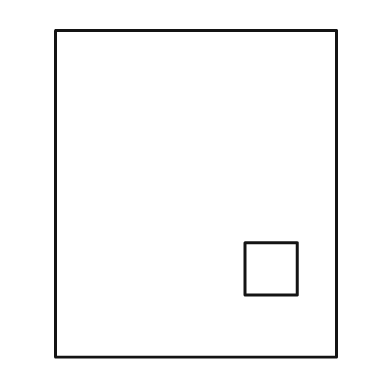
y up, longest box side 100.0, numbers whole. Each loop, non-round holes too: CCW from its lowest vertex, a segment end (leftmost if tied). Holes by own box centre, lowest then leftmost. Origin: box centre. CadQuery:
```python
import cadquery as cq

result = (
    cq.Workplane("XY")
    .moveTo(-43.0, -50.0)
    .lineTo(43.0, -50.0)
    .lineTo(43.0, 50.0)
    .lineTo(-43.0, 50.0)
    .close()
    .moveTo(15.0, -31.0)
    .lineTo(31.0, -31.0)
    .lineTo(31.0, -15.0)
    .lineTo(15.0, -15.0)
    .close()
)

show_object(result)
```